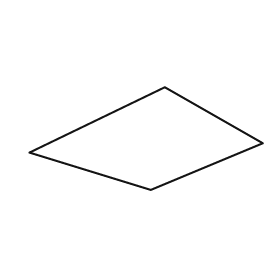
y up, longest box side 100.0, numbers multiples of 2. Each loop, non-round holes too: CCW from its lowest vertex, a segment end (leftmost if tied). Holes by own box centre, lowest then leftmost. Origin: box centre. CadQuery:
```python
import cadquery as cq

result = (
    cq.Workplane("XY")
    .moveTo(2.0, -22.0)
    .lineTo(50.0, -2.0)
    .lineTo(8.0, 22.0)
    .lineTo(-50.0, -6.0)
    .close()
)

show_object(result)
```